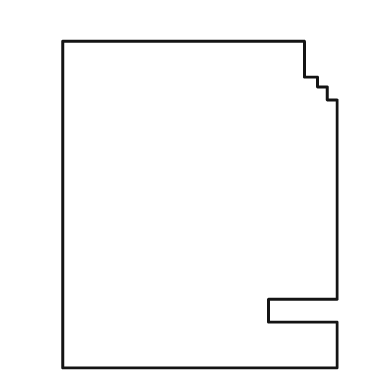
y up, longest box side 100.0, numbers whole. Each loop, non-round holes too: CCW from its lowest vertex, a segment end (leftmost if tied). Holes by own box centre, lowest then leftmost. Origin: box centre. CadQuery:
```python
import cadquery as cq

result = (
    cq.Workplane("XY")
    .moveTo(-42.0, -50.0)
    .lineTo(42.0, -50.0)
    .lineTo(42.0, -36.0)
    .lineTo(21.0, -36.0)
    .lineTo(21.0, -29.0)
    .lineTo(42.0, -29.0)
    .lineTo(42.0, 32.0)
    .lineTo(39.0, 32.0)
    .lineTo(39.0, 36.0)
    .lineTo(36.0, 36.0)
    .lineTo(36.0, 39.0)
    .lineTo(32.0, 39.0)
    .lineTo(32.0, 50.0)
    .lineTo(-42.0, 50.0)
    .close()
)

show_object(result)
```